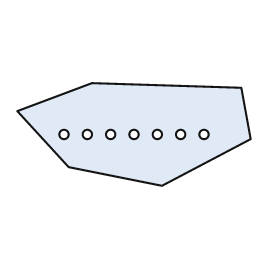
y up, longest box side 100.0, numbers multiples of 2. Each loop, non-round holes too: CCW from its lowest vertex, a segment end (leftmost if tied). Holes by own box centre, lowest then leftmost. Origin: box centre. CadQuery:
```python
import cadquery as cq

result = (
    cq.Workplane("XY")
    .moveTo(12.0, -22.0)
    .lineTo(50.0, -2.0)
    .lineTo(46.0, 20.0)
    .lineTo(-18.0, 22.0)
    .lineTo(-50.0, 10.0)
    .lineTo(-28.0, -14.0)
    .close()
    .moveTo(-30.0, 0.0)
    .circle(2.0)
    .moveTo(-20.0, 0.0)
    .circle(2.0)
    .moveTo(-10.0, 0.0)
    .circle(2.0)
    .moveTo(0.0, 0.0)
    .circle(2.0)
    .moveTo(10.0, 0.0)
    .circle(2.0)
    .moveTo(20.0, 0.0)
    .circle(2.0)
    .moveTo(30.0, 0.0)
    .circle(2.0)
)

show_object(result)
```